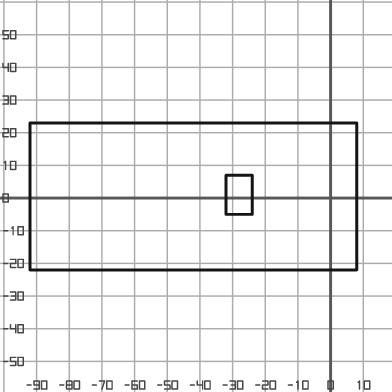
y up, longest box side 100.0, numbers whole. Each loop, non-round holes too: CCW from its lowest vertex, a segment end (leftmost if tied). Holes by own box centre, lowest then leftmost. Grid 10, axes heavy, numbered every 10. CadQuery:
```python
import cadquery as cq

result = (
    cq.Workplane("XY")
    .moveTo(-92.0, -22.0)
    .lineTo(8.0, -22.0)
    .lineTo(8.0, 23.0)
    .lineTo(-92.0, 23.0)
    .close()
    .moveTo(-32.0, -5.0)
    .lineTo(-24.0, -5.0)
    .lineTo(-24.0, 7.0)
    .lineTo(-32.0, 7.0)
    .close()
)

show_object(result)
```